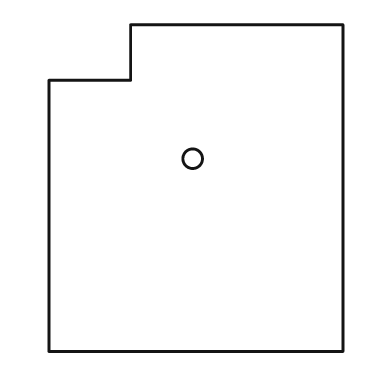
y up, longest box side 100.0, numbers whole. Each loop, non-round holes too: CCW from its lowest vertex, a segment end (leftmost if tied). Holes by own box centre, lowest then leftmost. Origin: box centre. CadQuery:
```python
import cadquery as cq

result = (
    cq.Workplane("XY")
    .moveTo(-45.0, -50.0)
    .lineTo(45.0, -50.0)
    .lineTo(45.0, 50.0)
    .lineTo(-20.0, 50.0)
    .lineTo(-20.0, 33.0)
    .lineTo(-45.0, 33.0)
    .close()
    .moveTo(-1.0, 9.0)
    .circle(3.0)
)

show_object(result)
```